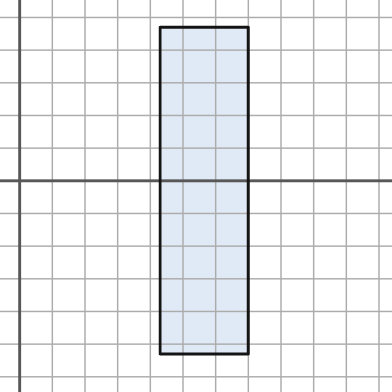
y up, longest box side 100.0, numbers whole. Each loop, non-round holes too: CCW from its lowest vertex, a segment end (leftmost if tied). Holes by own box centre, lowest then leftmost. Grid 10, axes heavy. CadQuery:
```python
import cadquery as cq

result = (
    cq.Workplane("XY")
    .moveTo(43.0, -53.0)
    .lineTo(70.0, -53.0)
    .lineTo(70.0, 47.0)
    .lineTo(43.0, 47.0)
    .close()
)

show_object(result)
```